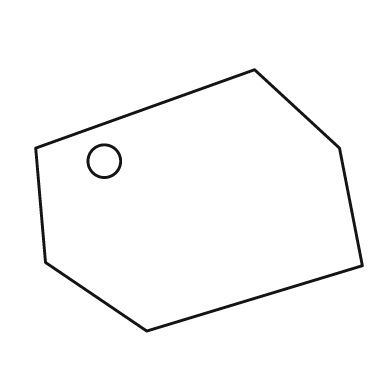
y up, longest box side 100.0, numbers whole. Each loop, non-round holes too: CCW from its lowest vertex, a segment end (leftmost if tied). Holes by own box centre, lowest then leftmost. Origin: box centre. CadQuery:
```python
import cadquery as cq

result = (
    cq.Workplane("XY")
    .moveTo(-16.0, -40.0)
    .lineTo(50.0, -20.0)
    .lineTo(43.0, 16.0)
    .lineTo(17.0, 40.0)
    .lineTo(-50.0, 16.0)
    .lineTo(-47.0, -19.0)
    .close()
    .moveTo(-29.0, 12.0)
    .circle(5.0)
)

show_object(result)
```